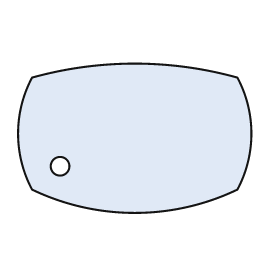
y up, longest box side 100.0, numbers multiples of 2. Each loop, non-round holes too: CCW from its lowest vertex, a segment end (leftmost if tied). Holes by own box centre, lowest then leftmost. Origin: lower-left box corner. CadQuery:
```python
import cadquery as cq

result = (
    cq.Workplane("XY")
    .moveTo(6.0, 10.0)
    .threePointArc((50.0, 0.0), (94.0, 10.0))
    .threePointArc((100.0, 34.0), (94.0, 58.0))
    .threePointArc((50.0, 64.0), (6.0, 58.0))
    .threePointArc((0.0, 34.0), (6.0, 10.0))
    .close()
    .moveTo(18.0, 20.0)
    .circle(4.0)
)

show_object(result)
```